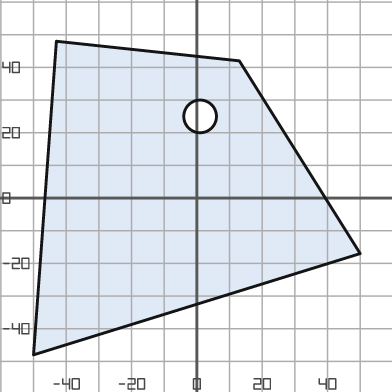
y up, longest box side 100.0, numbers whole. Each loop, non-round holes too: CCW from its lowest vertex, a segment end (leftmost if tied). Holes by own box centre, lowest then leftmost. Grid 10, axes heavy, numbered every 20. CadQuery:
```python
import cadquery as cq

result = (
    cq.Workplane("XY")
    .moveTo(-50.0, -48.0)
    .lineTo(50.0, -17.0)
    .lineTo(13.0, 42.0)
    .lineTo(-43.0, 48.0)
    .close()
    .moveTo(1.0, 25.0)
    .circle(5.0)
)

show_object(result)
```